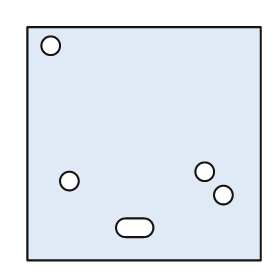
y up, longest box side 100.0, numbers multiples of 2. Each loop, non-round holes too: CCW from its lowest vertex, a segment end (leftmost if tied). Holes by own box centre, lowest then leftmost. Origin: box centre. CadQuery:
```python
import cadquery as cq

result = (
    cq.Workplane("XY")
    .moveTo(-50.0, -50.0)
    .lineTo(50.0, -50.0)
    .lineTo(50.0, 50.0)
    .lineTo(-50.0, 50.0)
    .close()
    .moveTo(-8.0, -40.0)
    .lineTo(0.0, -40.0)
    .threePointArc((4.0, -36.0), (0.0, -32.0))
    .lineTo(-8.0, -32.0)
    .threePointArc((-12.0, -36.0), (-8.0, -40.0))
    .close()
    .moveTo(34.0, -22.0)
    .circle(4.0)
    .moveTo(-32.0, -16.0)
    .circle(4.0)
    .moveTo(26.0, -12.0)
    .circle(4.0)
    .moveTo(-40.0, 42.0)
    .circle(4.0)
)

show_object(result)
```